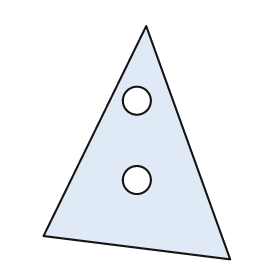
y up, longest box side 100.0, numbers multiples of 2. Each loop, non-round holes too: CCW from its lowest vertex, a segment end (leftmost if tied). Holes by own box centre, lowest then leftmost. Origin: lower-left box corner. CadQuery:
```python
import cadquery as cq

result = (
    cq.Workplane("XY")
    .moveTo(80.0, 0.0)
    .lineTo(44.0, 100.0)
    .lineTo(0.0, 10.0)
    .close()
    .moveTo(40.0, 34.0)
    .circle(6.0)
    .moveTo(40.0, 68.0)
    .circle(6.0)
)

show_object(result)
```